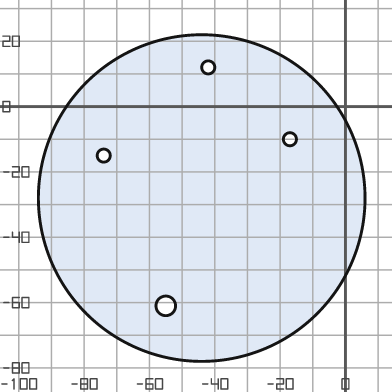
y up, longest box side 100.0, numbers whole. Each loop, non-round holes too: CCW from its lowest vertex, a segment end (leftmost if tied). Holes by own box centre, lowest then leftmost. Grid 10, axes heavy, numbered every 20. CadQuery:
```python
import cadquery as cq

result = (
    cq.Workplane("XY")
    .moveTo(-44.0, -28.0)
    .circle(50.0)
    .moveTo(-55.0, -61.0)
    .circle(3.0)
    .moveTo(-74.0, -15.0)
    .circle(2.0)
    .moveTo(-17.0, -10.0)
    .circle(2.0)
    .moveTo(-42.0, 12.0)
    .circle(2.0)
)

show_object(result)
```